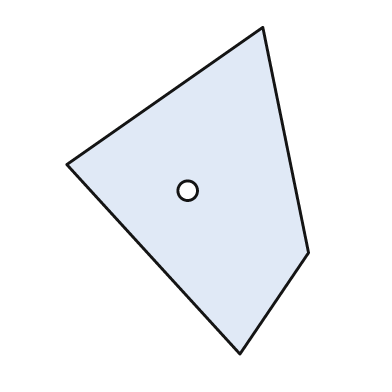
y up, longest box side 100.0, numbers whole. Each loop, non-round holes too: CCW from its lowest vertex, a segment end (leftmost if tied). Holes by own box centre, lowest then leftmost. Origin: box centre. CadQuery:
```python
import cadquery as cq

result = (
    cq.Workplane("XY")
    .moveTo(16.0, -50.0)
    .lineTo(37.0, -19.0)
    .lineTo(23.0, 50.0)
    .lineTo(-37.0, 8.0)
    .close()
    .moveTo(0.0, 0.0)
    .circle(3.0)
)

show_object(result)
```